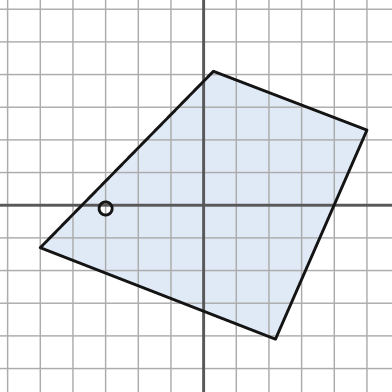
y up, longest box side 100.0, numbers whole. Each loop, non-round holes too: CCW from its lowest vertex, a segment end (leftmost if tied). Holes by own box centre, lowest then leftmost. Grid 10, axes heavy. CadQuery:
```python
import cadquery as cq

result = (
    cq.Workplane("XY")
    .moveTo(22.0, -41.0)
    .lineTo(50.0, 23.0)
    .lineTo(3.0, 41.0)
    .lineTo(-50.0, -13.0)
    .close()
    .moveTo(-30.0, -1.0)
    .circle(2.0)
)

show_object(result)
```